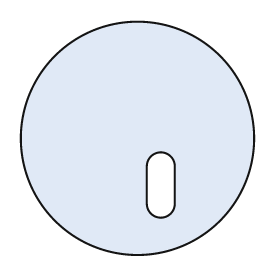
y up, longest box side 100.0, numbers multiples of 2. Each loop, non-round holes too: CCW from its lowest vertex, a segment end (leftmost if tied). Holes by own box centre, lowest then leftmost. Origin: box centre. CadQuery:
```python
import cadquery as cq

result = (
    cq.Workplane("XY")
    .moveTo(0.0, 0.0)
    .circle(50.0)
    .moveTo(4.0, -28.0)
    .threePointArc((10.0, -34.0), (16.0, -28.0))
    .lineTo(16.0, -12.0)
    .threePointArc((10.0, -6.0), (4.0, -12.0))
    .close()
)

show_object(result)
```